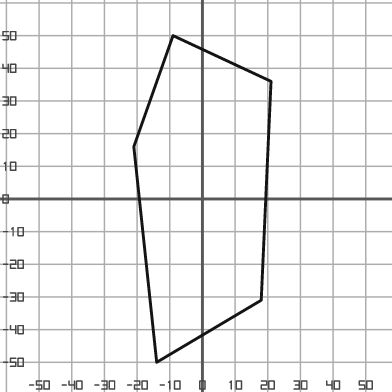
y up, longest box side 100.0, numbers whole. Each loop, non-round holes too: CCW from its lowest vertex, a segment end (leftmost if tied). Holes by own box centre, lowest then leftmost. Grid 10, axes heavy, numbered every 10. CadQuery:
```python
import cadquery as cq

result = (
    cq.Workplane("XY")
    .moveTo(-14.0, -50.0)
    .lineTo(18.0, -31.0)
    .lineTo(21.0, 36.0)
    .lineTo(-9.0, 50.0)
    .lineTo(-21.0, 16.0)
    .close()
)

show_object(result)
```